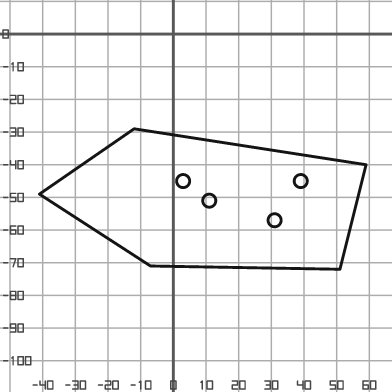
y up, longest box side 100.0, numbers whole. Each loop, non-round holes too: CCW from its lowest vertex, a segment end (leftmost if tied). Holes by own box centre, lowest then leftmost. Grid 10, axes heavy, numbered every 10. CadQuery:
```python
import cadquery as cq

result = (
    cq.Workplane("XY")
    .moveTo(51.0, -72.0)
    .lineTo(59.0, -40.0)
    .lineTo(-12.0, -29.0)
    .lineTo(-41.0, -49.0)
    .lineTo(-7.0, -71.0)
    .close()
    .moveTo(31.0, -57.0)
    .circle(2.0)
    .moveTo(11.0, -51.0)
    .circle(2.0)
    .moveTo(3.0, -45.0)
    .circle(2.0)
    .moveTo(39.0, -45.0)
    .circle(2.0)
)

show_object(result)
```